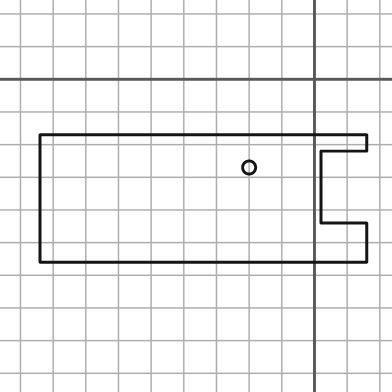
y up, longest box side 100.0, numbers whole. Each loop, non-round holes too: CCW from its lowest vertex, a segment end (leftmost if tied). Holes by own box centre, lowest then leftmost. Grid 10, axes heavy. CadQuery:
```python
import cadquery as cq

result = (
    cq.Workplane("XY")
    .moveTo(-84.0, -56.0)
    .lineTo(16.0, -56.0)
    .lineTo(16.0, -44.0)
    .lineTo(2.0, -44.0)
    .lineTo(2.0, -22.0)
    .lineTo(16.0, -22.0)
    .lineTo(16.0, -17.0)
    .lineTo(-84.0, -17.0)
    .close()
    .moveTo(-20.0, -27.0)
    .circle(2.0)
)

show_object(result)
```